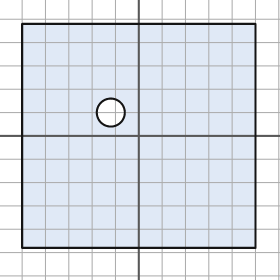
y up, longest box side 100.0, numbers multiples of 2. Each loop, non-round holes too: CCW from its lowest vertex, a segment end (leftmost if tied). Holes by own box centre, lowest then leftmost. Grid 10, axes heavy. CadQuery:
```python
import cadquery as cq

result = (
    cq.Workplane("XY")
    .moveTo(-50.0, -48.0)
    .lineTo(50.0, -48.0)
    .lineTo(50.0, 48.0)
    .lineTo(-50.0, 48.0)
    .close()
    .moveTo(-12.0, 10.0)
    .circle(6.0)
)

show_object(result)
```